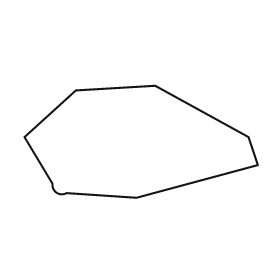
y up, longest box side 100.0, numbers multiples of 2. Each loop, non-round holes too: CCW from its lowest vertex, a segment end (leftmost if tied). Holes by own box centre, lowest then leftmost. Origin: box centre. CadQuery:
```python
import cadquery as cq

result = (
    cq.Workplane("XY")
    .moveTo(-2.0, -24.0)
    .lineTo(50.0, -10.0)
    .lineTo(46.0, 2.0)
    .lineTo(6.0, 24.0)
    .lineTo(-28.0, 22.0)
    .lineTo(-50.0, 2.0)
    .lineTo(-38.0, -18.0)
    .threePointArc((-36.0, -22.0), (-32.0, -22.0))
    .close()
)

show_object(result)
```